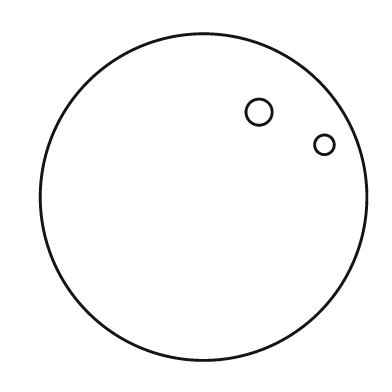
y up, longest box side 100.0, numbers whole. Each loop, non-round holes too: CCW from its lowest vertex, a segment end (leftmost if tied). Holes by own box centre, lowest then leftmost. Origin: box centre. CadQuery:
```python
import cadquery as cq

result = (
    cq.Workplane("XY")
    .moveTo(0.0, 0.0)
    .circle(50.0)
    .moveTo(37.0, 16.0)
    .circle(3.0)
    .moveTo(17.0, 26.0)
    .circle(4.0)
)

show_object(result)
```